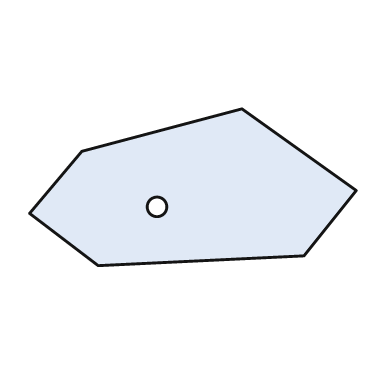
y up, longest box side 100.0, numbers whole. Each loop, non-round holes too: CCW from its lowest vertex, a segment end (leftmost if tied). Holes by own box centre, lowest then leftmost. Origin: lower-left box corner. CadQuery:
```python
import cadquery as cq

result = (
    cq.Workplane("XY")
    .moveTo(21.0, 0.0)
    .lineTo(84.0, 3.0)
    .lineTo(100.0, 23.0)
    .lineTo(65.0, 48.0)
    .lineTo(16.0, 35.0)
    .lineTo(0.0, 16.0)
    .close()
    .moveTo(39.0, 18.0)
    .circle(3.0)
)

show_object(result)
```